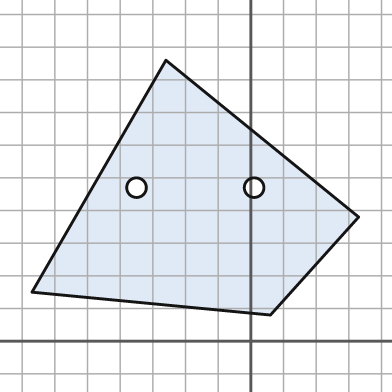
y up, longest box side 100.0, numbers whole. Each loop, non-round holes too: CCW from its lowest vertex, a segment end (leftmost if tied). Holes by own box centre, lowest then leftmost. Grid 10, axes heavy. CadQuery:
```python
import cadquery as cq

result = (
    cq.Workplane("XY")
    .moveTo(6.0, 8.0)
    .lineTo(33.0, 38.0)
    .lineTo(-26.0, 86.0)
    .lineTo(-67.0, 15.0)
    .close()
    .moveTo(-35.0, 47.0)
    .circle(3.0)
    .moveTo(1.0, 47.0)
    .circle(3.0)
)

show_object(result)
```